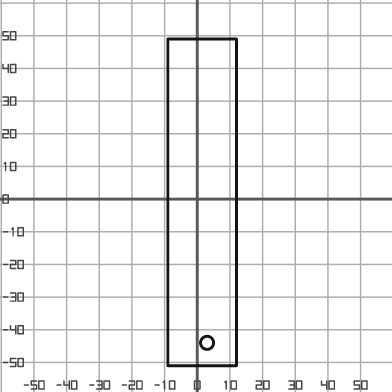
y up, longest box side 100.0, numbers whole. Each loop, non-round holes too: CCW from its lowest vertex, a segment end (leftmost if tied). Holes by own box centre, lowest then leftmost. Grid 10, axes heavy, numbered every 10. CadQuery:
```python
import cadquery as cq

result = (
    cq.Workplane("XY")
    .moveTo(-9.0, -51.0)
    .lineTo(12.0, -51.0)
    .lineTo(12.0, 49.0)
    .lineTo(-9.0, 49.0)
    .close()
    .moveTo(3.0, -44.0)
    .circle(2.0)
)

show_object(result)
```